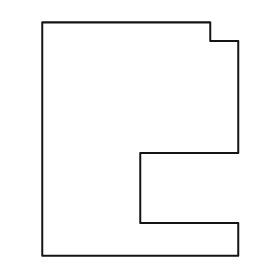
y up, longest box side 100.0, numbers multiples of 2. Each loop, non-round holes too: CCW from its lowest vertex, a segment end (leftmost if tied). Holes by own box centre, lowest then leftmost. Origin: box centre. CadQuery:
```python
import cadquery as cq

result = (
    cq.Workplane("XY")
    .moveTo(-42.0, -50.0)
    .lineTo(42.0, -50.0)
    .lineTo(42.0, -36.0)
    .lineTo(0.0, -36.0)
    .lineTo(0.0, -6.0)
    .lineTo(42.0, -6.0)
    .lineTo(42.0, 42.0)
    .lineTo(30.0, 42.0)
    .lineTo(30.0, 50.0)
    .lineTo(-42.0, 50.0)
    .close()
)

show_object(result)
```